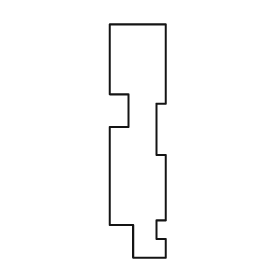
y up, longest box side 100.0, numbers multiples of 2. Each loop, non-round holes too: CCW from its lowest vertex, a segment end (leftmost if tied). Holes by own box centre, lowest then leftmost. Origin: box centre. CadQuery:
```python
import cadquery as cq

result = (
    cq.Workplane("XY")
    .moveTo(-2.0, -50.0)
    .lineTo(12.0, -50.0)
    .lineTo(12.0, -42.0)
    .lineTo(8.0, -42.0)
    .lineTo(8.0, -34.0)
    .lineTo(12.0, -34.0)
    .lineTo(12.0, -6.0)
    .lineTo(8.0, -6.0)
    .lineTo(8.0, 16.0)
    .lineTo(12.0, 16.0)
    .lineTo(12.0, 50.0)
    .lineTo(-12.0, 50.0)
    .lineTo(-12.0, 20.0)
    .lineTo(-4.0, 20.0)
    .lineTo(-4.0, 6.0)
    .lineTo(-12.0, 6.0)
    .lineTo(-12.0, -36.0)
    .lineTo(-2.0, -36.0)
    .close()
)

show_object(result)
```